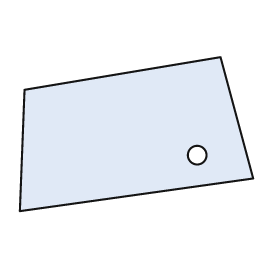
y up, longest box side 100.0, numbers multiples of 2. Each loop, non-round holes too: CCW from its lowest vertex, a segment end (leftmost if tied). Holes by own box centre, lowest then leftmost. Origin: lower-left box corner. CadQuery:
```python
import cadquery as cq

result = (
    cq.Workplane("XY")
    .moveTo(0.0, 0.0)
    .lineTo(100.0, 14.0)
    .lineTo(86.0, 66.0)
    .lineTo(2.0, 52.0)
    .close()
    .moveTo(76.0, 24.0)
    .circle(4.0)
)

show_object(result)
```